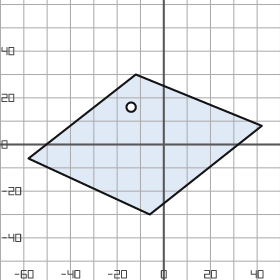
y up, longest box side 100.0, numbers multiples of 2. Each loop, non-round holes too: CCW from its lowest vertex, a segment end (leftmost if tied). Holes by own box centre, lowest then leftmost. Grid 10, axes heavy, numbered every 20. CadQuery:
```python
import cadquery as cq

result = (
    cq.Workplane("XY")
    .moveTo(-6.0, -30.0)
    .lineTo(42.0, 8.0)
    .lineTo(-12.0, 30.0)
    .lineTo(-58.0, -6.0)
    .close()
    .moveTo(-14.0, 16.0)
    .circle(2.0)
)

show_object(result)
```